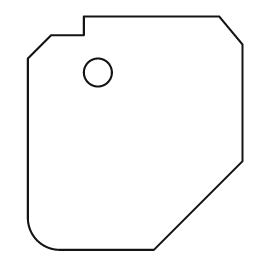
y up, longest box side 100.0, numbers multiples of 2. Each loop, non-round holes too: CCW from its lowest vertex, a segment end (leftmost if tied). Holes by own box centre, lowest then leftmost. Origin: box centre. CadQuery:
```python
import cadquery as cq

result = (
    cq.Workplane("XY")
    .moveTo(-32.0, -50.0)
    .lineTo(8.0, -50.0)
    .lineTo(46.0, -12.0)
    .lineTo(46.0, 38.0)
    .lineTo(36.0, 50.0)
    .lineTo(-22.0, 50.0)
    .lineTo(-22.0, 42.0)
    .lineTo(-36.0, 42.0)
    .lineTo(-46.0, 32.0)
    .lineTo(-46.0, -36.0)
    .threePointArc((-42.0, -46.0), (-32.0, -50.0))
    .close()
    .moveTo(-16.0, 26.0)
    .circle(6.0)
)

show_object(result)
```